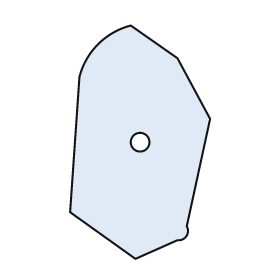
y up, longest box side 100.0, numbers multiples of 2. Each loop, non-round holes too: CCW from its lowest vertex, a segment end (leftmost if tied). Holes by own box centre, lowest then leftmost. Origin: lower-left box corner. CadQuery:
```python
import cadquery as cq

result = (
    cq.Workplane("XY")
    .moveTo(28.0, 0.0)
    .lineTo(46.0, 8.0)
    .threePointArc((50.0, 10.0), (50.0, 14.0))
    .lineTo(60.0, 60.0)
    .lineTo(46.0, 86.0)
    .lineTo(26.0, 100.0)
    .threePointArc((12.0, 92.0), (4.0, 78.0))
    .lineTo(0.0, 20.0)
    .close()
    .moveTo(30.0, 50.0)
    .circle(4.0)
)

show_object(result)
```